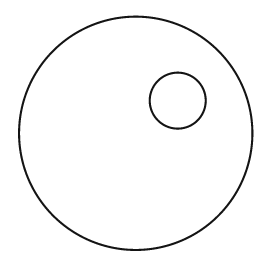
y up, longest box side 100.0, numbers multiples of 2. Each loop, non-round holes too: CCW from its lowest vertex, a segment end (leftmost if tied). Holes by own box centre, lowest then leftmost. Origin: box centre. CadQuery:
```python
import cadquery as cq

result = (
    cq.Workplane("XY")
    .moveTo(0.0, 0.0)
    .circle(50.0)
    .moveTo(18.0, 14.0)
    .circle(12.0)
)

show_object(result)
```